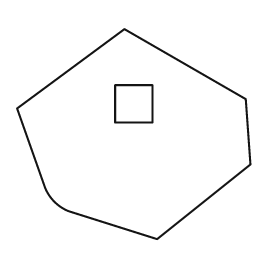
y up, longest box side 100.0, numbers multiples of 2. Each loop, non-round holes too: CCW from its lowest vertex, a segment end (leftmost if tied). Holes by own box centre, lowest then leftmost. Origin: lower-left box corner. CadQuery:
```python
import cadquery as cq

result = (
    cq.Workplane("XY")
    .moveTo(60.0, 0.0)
    .lineTo(100.0, 32.0)
    .lineTo(98.0, 60.0)
    .lineTo(46.0, 90.0)
    .lineTo(0.0, 56.0)
    .lineTo(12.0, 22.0)
    .threePointArc((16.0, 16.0), (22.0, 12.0))
    .close()
    .moveTo(42.0, 50.0)
    .lineTo(58.0, 50.0)
    .lineTo(58.0, 66.0)
    .lineTo(42.0, 66.0)
    .close()
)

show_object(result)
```